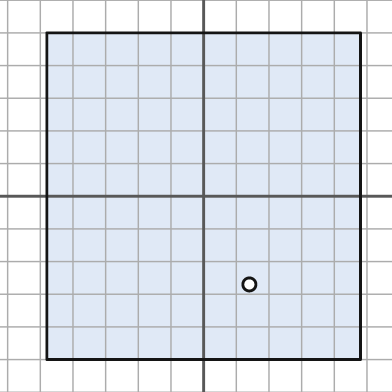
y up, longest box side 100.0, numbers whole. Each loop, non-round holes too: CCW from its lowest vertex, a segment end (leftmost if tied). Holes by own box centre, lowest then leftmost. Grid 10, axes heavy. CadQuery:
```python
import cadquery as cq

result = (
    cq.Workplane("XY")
    .moveTo(-48.0, -50.0)
    .lineTo(48.0, -50.0)
    .lineTo(48.0, 50.0)
    .lineTo(-48.0, 50.0)
    .close()
    .moveTo(14.0, -27.0)
    .circle(2.0)
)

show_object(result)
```